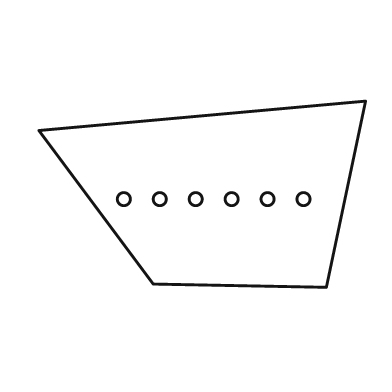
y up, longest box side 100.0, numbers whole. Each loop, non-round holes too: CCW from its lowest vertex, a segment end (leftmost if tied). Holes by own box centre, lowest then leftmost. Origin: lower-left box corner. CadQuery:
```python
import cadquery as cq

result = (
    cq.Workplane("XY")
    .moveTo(88.0, 0.0)
    .lineTo(100.0, 57.0)
    .lineTo(0.0, 48.0)
    .lineTo(35.0, 1.0)
    .close()
    .moveTo(26.0, 27.0)
    .circle(2.0)
    .moveTo(37.0, 27.0)
    .circle(2.0)
    .moveTo(48.0, 27.0)
    .circle(2.0)
    .moveTo(59.0, 27.0)
    .circle(2.0)
    .moveTo(70.0, 27.0)
    .circle(2.0)
    .moveTo(81.0, 27.0)
    .circle(2.0)
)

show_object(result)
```